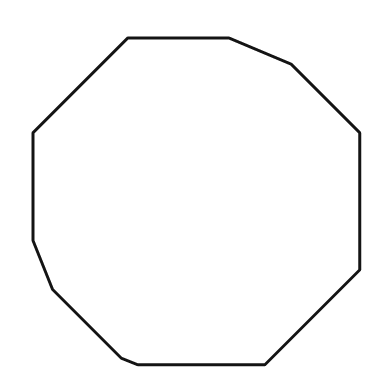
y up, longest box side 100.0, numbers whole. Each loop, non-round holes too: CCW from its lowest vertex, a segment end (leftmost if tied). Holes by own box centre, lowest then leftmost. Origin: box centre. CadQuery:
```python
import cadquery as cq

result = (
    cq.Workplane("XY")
    .moveTo(-18.0, -50.0)
    .lineTo(21.0, -50.0)
    .lineTo(50.0, -21.0)
    .lineTo(50.0, 21.0)
    .lineTo(29.0, 42.0)
    .lineTo(10.0, 50.0)
    .lineTo(-21.0, 50.0)
    .lineTo(-50.0, 21.0)
    .lineTo(-50.0, -12.0)
    .lineTo(-44.0, -27.0)
    .lineTo(-23.0, -48.0)
    .close()
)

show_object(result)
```